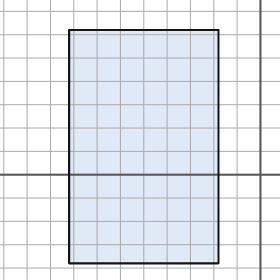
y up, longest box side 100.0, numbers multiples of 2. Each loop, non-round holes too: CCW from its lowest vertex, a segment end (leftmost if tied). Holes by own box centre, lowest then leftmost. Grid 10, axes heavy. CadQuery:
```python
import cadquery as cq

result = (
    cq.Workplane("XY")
    .moveTo(-82.0, -38.0)
    .lineTo(-18.0, -38.0)
    .lineTo(-18.0, 62.0)
    .lineTo(-82.0, 62.0)
    .close()
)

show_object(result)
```